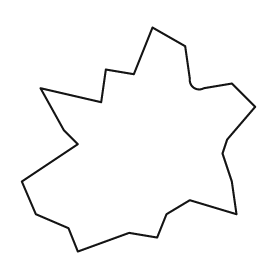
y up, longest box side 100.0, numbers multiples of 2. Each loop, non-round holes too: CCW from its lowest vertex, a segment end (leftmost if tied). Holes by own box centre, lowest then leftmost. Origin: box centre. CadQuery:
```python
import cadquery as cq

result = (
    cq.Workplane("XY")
    .moveTo(-26.0, -48.0)
    .lineTo(-4.0, -40.0)
    .lineTo(8.0, -42.0)
    .lineTo(12.0, -32.0)
    .lineTo(22.0, -26.0)
    .lineTo(42.0, -32.0)
    .lineTo(40.0, -18.0)
    .lineTo(36.0, -6.0)
    .lineTo(38.0, 0.0)
    .lineTo(50.0, 14.0)
    .lineTo(40.0, 24.0)
    .lineTo(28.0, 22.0)
    .threePointArc((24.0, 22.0), (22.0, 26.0))
    .lineTo(20.0, 40.0)
    .lineTo(6.0, 48.0)
    .lineTo(-2.0, 28.0)
    .lineTo(-14.0, 30.0)
    .lineTo(-16.0, 16.0)
    .lineTo(-42.0, 22.0)
    .lineTo(-32.0, 4.0)
    .lineTo(-26.0, -2.0)
    .lineTo(-50.0, -18.0)
    .lineTo(-44.0, -32.0)
    .lineTo(-30.0, -38.0)
    .close()
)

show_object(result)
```